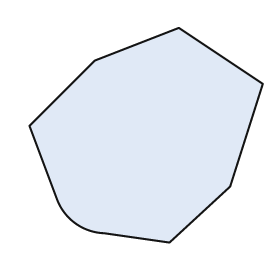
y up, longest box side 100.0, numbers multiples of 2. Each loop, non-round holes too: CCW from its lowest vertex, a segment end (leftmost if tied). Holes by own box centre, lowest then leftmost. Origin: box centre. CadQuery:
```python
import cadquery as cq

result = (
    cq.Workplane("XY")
    .moveTo(10.0, -46.0)
    .lineTo(36.0, -22.0)
    .lineTo(50.0, 22.0)
    .lineTo(14.0, 46.0)
    .lineTo(-22.0, 32.0)
    .lineTo(-50.0, 4.0)
    .lineTo(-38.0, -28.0)
    .threePointArc((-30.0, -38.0), (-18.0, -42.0))
    .close()
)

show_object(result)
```